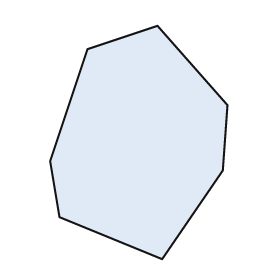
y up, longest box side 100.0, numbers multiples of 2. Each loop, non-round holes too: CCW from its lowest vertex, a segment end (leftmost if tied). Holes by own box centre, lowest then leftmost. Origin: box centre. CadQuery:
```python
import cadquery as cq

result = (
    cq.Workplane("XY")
    .moveTo(10.0, -50.0)
    .lineTo(36.0, -12.0)
    .lineTo(38.0, 16.0)
    .lineTo(8.0, 50.0)
    .lineTo(-22.0, 40.0)
    .lineTo(-38.0, -8.0)
    .lineTo(-34.0, -32.0)
    .close()
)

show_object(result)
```